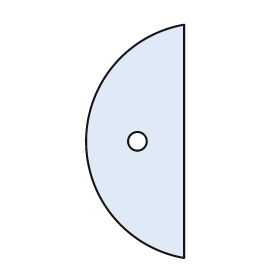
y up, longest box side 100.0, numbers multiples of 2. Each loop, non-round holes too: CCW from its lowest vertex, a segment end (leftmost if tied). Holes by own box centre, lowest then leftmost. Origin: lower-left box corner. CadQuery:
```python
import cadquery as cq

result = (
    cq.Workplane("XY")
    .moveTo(42.0, 0.0)
    .lineTo(42.0, 100.0)
    .threePointArc((0.0, 50.0), (42.0, 0.0))
    .close()
    .moveTo(22.0, 50.0)
    .circle(4.0)
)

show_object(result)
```